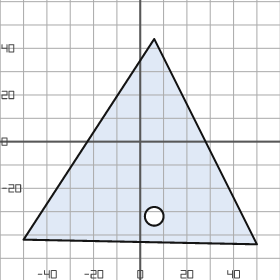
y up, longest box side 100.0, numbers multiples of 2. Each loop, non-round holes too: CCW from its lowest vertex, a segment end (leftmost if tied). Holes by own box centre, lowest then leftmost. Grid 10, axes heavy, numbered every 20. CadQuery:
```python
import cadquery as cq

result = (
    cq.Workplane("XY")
    .moveTo(50.0, -44.0)
    .lineTo(6.0, 44.0)
    .lineTo(-50.0, -42.0)
    .close()
    .moveTo(6.0, -32.0)
    .circle(4.0)
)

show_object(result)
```